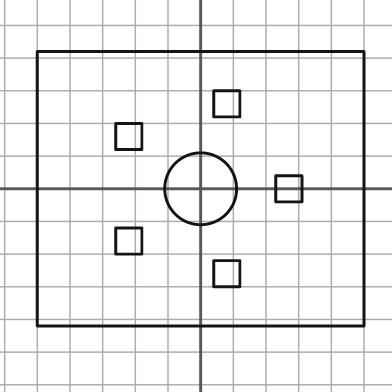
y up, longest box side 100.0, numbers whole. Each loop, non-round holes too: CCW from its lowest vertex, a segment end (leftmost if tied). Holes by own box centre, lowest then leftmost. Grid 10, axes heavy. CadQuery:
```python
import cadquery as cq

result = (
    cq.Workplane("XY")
    .moveTo(-50.0, -42.0)
    .lineTo(50.0, -42.0)
    .lineTo(50.0, 42.0)
    .lineTo(-50.0, 42.0)
    .close()
    .moveTo(4.0, -30.0)
    .lineTo(12.0, -30.0)
    .lineTo(12.0, -22.0)
    .lineTo(4.0, -22.0)
    .close()
    .moveTo(-26.0, -20.0)
    .lineTo(-18.0, -20.0)
    .lineTo(-18.0, -12.0)
    .lineTo(-26.0, -12.0)
    .close()
    .moveTo(0.0, 0.0)
    .circle(11.0)
    .moveTo(23.0, -4.0)
    .lineTo(31.0, -4.0)
    .lineTo(31.0, 4.0)
    .lineTo(23.0, 4.0)
    .close()
    .moveTo(-26.0, 12.0)
    .lineTo(-18.0, 12.0)
    .lineTo(-18.0, 20.0)
    .lineTo(-26.0, 20.0)
    .close()
    .moveTo(4.0, 22.0)
    .lineTo(12.0, 22.0)
    .lineTo(12.0, 30.0)
    .lineTo(4.0, 30.0)
    .close()
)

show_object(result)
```